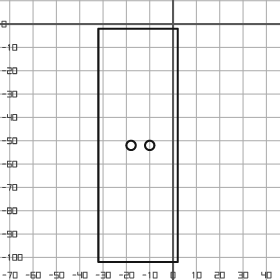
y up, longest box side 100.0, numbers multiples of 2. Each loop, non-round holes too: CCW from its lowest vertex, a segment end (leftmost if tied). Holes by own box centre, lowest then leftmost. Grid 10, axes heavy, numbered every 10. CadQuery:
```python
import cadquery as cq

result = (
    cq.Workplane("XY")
    .moveTo(-32.0, -102.0)
    .lineTo(2.0, -102.0)
    .lineTo(2.0, -2.0)
    .lineTo(-32.0, -2.0)
    .close()
    .moveTo(-18.0, -52.0)
    .circle(2.0)
    .moveTo(-10.0, -52.0)
    .circle(2.0)
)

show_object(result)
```